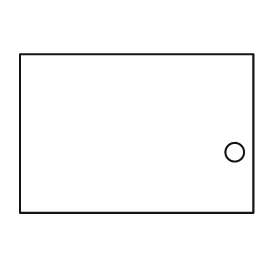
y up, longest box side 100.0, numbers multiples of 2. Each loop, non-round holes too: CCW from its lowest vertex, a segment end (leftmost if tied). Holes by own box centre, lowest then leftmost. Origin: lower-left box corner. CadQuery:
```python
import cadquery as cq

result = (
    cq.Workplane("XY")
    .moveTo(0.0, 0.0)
    .lineTo(100.0, 0.0)
    .lineTo(100.0, 68.0)
    .lineTo(0.0, 68.0)
    .close()
    .moveTo(92.0, 26.0)
    .circle(4.0)
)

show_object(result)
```